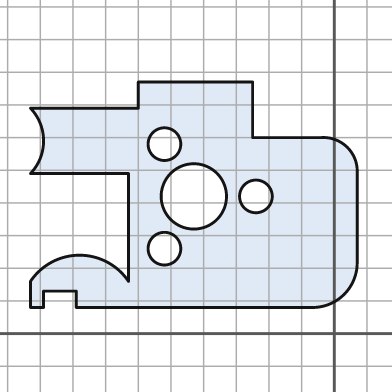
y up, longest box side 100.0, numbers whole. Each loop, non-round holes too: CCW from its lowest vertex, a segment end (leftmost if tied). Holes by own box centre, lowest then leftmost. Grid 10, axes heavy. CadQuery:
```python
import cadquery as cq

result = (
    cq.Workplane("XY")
    .moveTo(-93.0, 8.0)
    .lineTo(-89.0, 8.0)
    .lineTo(-89.0, 13.0)
    .lineTo(-79.0, 13.0)
    .lineTo(-79.0, 8.0)
    .lineTo(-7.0, 8.0)
    .threePointArc((3.0, 12.0), (7.0, 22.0))
    .lineTo(7.0, 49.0)
    .threePointArc((4.0, 57.0), (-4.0, 60.0))
    .lineTo(-25.0, 60.0)
    .lineTo(-25.0, 77.0)
    .lineTo(-60.0, 77.0)
    .lineTo(-60.0, 69.0)
    .lineTo(-93.0, 69.0)
    .threePointArc((-89.0, 59.0), (-93.0, 49.0))
    .lineTo(-63.0, 49.0)
    .lineTo(-63.0, 16.0)
    .threePointArc((-78.0, 24.0), (-93.0, 16.0))
    .close()
    .moveTo(-52.0, 26.0)
    .circle(5.0)
    .moveTo(-43.0, 42.0)
    .circle(10.0)
    .moveTo(-24.0, 42.0)
    .circle(5.0)
    .moveTo(-52.0, 58.0)
    .circle(5.0)
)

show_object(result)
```